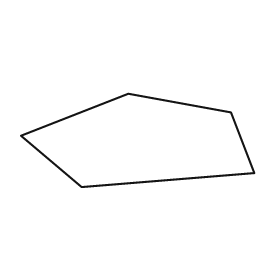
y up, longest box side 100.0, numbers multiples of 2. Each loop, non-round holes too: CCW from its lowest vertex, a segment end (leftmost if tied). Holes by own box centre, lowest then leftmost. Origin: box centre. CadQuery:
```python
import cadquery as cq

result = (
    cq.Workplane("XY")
    .moveTo(-24.0, -20.0)
    .lineTo(50.0, -14.0)
    .lineTo(40.0, 12.0)
    .lineTo(-4.0, 20.0)
    .lineTo(-50.0, 2.0)
    .close()
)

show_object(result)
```